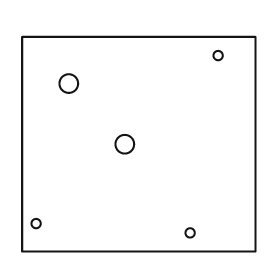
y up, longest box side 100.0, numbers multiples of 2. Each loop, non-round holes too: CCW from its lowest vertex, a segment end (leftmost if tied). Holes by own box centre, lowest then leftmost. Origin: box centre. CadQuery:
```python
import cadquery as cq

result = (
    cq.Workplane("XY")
    .moveTo(-50.0, -46.0)
    .lineTo(50.0, -46.0)
    .lineTo(50.0, 46.0)
    .lineTo(-50.0, 46.0)
    .close()
    .moveTo(22.0, -38.0)
    .circle(2.0)
    .moveTo(-44.0, -34.0)
    .circle(2.0)
    .moveTo(-6.0, 0.0)
    .circle(4.0)
    .moveTo(-30.0, 26.0)
    .circle(4.0)
    .moveTo(34.0, 38.0)
    .circle(2.0)
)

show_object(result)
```